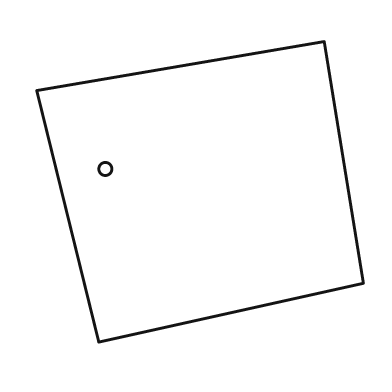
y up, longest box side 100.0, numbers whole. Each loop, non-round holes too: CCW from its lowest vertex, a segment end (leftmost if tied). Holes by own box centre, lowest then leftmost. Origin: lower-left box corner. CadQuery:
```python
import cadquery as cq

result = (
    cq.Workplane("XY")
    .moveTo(19.0, 0.0)
    .lineTo(100.0, 18.0)
    .lineTo(88.0, 92.0)
    .lineTo(0.0, 77.0)
    .close()
    .moveTo(21.0, 53.0)
    .circle(2.0)
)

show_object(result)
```